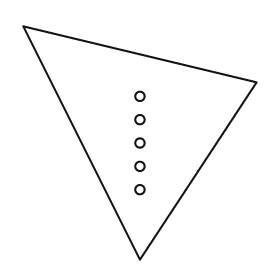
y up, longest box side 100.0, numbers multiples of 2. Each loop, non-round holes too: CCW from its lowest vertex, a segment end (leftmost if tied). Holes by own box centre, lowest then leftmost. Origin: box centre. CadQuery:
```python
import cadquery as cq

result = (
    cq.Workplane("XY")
    .moveTo(0.0, -50.0)
    .lineTo(50.0, 26.0)
    .lineTo(-50.0, 50.0)
    .close()
    .moveTo(0.0, -20.0)
    .circle(2.0)
    .moveTo(0.0, -10.0)
    .circle(2.0)
    .moveTo(0.0, 0.0)
    .circle(2.0)
    .moveTo(0.0, 10.0)
    .circle(2.0)
    .moveTo(0.0, 20.0)
    .circle(2.0)
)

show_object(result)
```